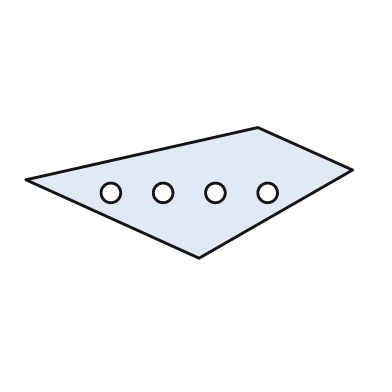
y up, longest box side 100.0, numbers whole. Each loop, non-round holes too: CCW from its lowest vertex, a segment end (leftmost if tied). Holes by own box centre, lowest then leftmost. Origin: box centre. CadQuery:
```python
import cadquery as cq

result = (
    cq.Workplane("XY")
    .moveTo(3.0, -20.0)
    .lineTo(50.0, 7.0)
    .lineTo(21.0, 20.0)
    .lineTo(-50.0, 4.0)
    .close()
    .moveTo(-24.0, 0.0)
    .circle(3.0)
    .moveTo(-8.0, 0.0)
    .circle(3.0)
    .moveTo(8.0, 0.0)
    .circle(3.0)
    .moveTo(24.0, 0.0)
    .circle(3.0)
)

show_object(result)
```